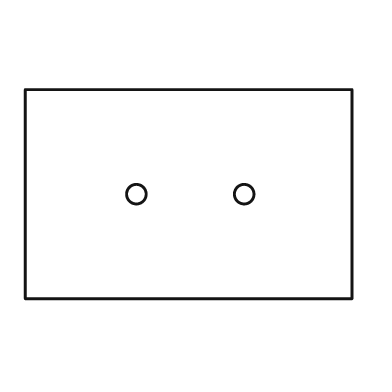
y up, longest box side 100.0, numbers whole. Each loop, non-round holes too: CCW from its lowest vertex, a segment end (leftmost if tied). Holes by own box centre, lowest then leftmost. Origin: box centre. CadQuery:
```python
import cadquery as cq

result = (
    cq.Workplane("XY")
    .moveTo(-50.0, -32.0)
    .lineTo(50.0, -32.0)
    .lineTo(50.0, 32.0)
    .lineTo(-50.0, 32.0)
    .close()
    .moveTo(-16.0, 0.0)
    .circle(3.0)
    .moveTo(17.0, 0.0)
    .circle(3.0)
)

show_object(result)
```